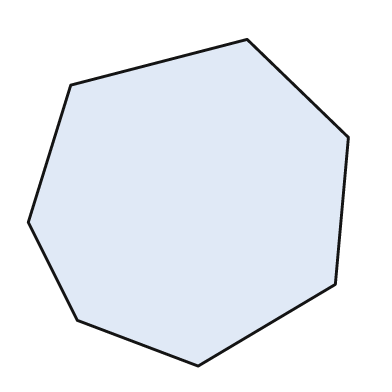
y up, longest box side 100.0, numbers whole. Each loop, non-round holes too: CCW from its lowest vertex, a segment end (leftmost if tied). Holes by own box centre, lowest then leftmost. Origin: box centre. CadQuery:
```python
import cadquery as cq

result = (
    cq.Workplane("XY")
    .moveTo(3.0, -50.0)
    .lineTo(45.0, -25.0)
    .lineTo(49.0, 20.0)
    .lineTo(18.0, 50.0)
    .lineTo(-36.0, 36.0)
    .lineTo(-49.0, -6.0)
    .lineTo(-34.0, -36.0)
    .close()
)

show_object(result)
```